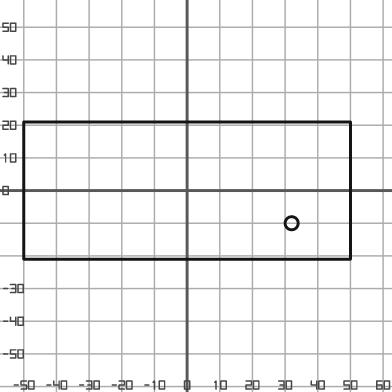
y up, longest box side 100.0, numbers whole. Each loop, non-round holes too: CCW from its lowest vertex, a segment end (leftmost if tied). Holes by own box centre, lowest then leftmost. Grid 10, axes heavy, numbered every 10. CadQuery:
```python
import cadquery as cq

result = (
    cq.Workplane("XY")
    .moveTo(-50.0, -21.0)
    .lineTo(50.0, -21.0)
    .lineTo(50.0, 21.0)
    .lineTo(-50.0, 21.0)
    .close()
    .moveTo(32.0, -10.0)
    .circle(2.0)
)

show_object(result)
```